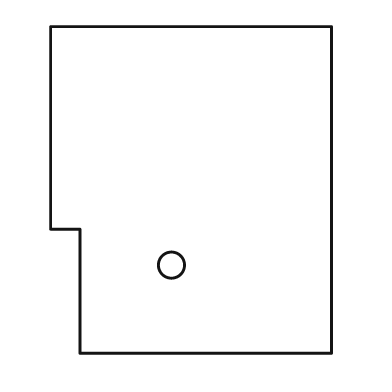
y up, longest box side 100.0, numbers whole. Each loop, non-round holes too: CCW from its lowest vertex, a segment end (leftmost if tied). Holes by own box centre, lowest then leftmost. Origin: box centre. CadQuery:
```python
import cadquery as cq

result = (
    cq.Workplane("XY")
    .moveTo(-34.0, -50.0)
    .lineTo(43.0, -50.0)
    .lineTo(43.0, 50.0)
    .lineTo(-43.0, 50.0)
    .lineTo(-43.0, -12.0)
    .lineTo(-34.0, -12.0)
    .close()
    .moveTo(-6.0, -23.0)
    .circle(4.0)
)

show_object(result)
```